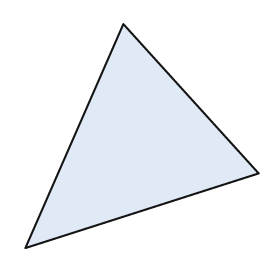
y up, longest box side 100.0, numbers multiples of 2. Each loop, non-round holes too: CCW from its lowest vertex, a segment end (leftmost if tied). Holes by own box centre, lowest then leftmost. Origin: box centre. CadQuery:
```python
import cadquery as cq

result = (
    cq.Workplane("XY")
    .moveTo(-50.0, -48.0)
    .lineTo(50.0, -16.0)
    .lineTo(-8.0, 48.0)
    .close()
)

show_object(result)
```